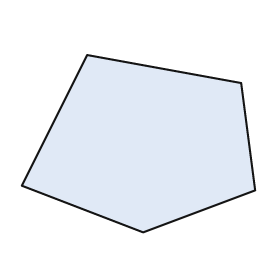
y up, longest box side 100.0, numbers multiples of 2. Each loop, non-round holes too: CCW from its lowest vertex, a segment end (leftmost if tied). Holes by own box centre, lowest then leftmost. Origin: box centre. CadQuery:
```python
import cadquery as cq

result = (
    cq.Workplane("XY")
    .moveTo(2.0, -38.0)
    .lineTo(50.0, -20.0)
    .lineTo(44.0, 26.0)
    .lineTo(-22.0, 38.0)
    .lineTo(-50.0, -18.0)
    .close()
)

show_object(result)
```